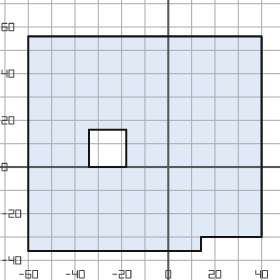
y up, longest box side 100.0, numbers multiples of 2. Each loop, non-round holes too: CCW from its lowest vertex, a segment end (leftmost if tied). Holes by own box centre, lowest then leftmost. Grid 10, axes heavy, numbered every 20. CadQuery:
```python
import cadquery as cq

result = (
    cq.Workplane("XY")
    .moveTo(-60.0, -36.0)
    .lineTo(14.0, -36.0)
    .lineTo(14.0, -30.0)
    .lineTo(40.0, -30.0)
    .lineTo(40.0, 56.0)
    .lineTo(-60.0, 56.0)
    .close()
    .moveTo(-34.0, 0.0)
    .lineTo(-18.0, 0.0)
    .lineTo(-18.0, 16.0)
    .lineTo(-34.0, 16.0)
    .close()
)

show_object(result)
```